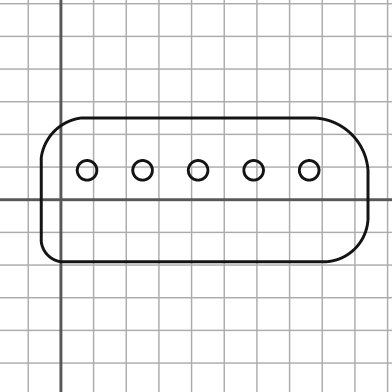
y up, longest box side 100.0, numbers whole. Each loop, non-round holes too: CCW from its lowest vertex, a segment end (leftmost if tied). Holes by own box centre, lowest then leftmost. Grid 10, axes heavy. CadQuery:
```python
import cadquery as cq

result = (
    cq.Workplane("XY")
    .moveTo(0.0, -19.0)
    .lineTo(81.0, -19.0)
    .threePointArc((90.0, -15.0), (94.0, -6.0))
    .lineTo(94.0, 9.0)
    .threePointArc((89.0, 20.0), (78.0, 25.0))
    .lineTo(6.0, 25.0)
    .threePointArc((-2.0, 21.0), (-6.0, 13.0))
    .lineTo(-6.0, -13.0)
    .threePointArc((-4.0, -17.0), (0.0, -19.0))
    .close()
    .moveTo(8.0, 9.0)
    .circle(3.0)
    .moveTo(25.0, 9.0)
    .circle(3.0)
    .moveTo(42.0, 9.0)
    .circle(3.0)
    .moveTo(59.0, 9.0)
    .circle(3.0)
    .moveTo(76.0, 9.0)
    .circle(3.0)
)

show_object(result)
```